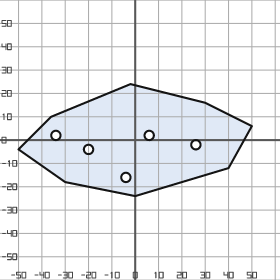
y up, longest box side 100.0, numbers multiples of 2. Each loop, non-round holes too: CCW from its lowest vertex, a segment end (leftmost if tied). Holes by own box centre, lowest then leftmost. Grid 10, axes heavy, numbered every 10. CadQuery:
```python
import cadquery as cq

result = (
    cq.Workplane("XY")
    .moveTo(0.0, -24.0)
    .lineTo(40.0, -12.0)
    .lineTo(50.0, 6.0)
    .lineTo(30.0, 16.0)
    .lineTo(-2.0, 24.0)
    .lineTo(-36.0, 10.0)
    .lineTo(-50.0, -4.0)
    .lineTo(-30.0, -18.0)
    .close()
    .moveTo(-4.0, -16.0)
    .circle(2.0)
    .moveTo(-20.0, -4.0)
    .circle(2.0)
    .moveTo(26.0, -2.0)
    .circle(2.0)
    .moveTo(-34.0, 2.0)
    .circle(2.0)
    .moveTo(6.0, 2.0)
    .circle(2.0)
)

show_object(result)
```